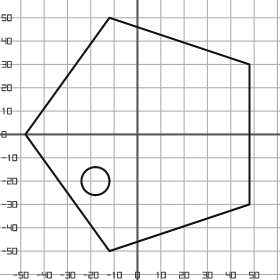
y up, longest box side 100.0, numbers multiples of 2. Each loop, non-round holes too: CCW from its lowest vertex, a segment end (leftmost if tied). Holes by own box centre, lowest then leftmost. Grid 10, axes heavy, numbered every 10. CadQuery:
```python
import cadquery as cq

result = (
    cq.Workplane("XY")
    .moveTo(-12.0, -50.0)
    .lineTo(48.0, -30.0)
    .lineTo(48.0, 30.0)
    .lineTo(-12.0, 50.0)
    .lineTo(-48.0, 0.0)
    .close()
    .moveTo(-18.0, -20.0)
    .circle(6.0)
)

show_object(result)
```